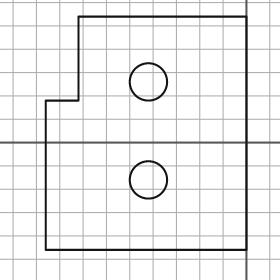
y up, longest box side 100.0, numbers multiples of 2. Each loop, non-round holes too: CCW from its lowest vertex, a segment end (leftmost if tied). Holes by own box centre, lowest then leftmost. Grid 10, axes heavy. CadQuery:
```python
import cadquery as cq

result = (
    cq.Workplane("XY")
    .moveTo(-86.0, -46.0)
    .lineTo(0.0, -46.0)
    .lineTo(0.0, 54.0)
    .lineTo(-72.0, 54.0)
    .lineTo(-72.0, 18.0)
    .lineTo(-86.0, 18.0)
    .close()
    .moveTo(-42.0, -16.0)
    .circle(8.0)
    .moveTo(-42.0, 26.0)
    .circle(8.0)
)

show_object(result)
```